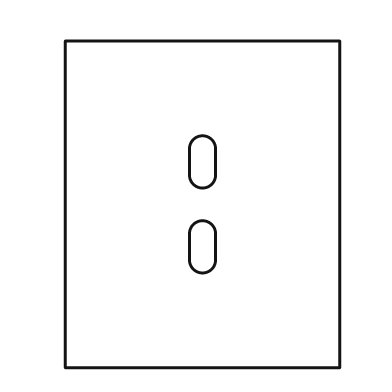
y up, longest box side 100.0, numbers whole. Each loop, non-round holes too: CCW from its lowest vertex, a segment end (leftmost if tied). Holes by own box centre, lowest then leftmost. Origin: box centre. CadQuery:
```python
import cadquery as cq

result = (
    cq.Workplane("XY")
    .moveTo(-42.0, -50.0)
    .lineTo(42.0, -50.0)
    .lineTo(42.0, 50.0)
    .lineTo(-42.0, 50.0)
    .close()
    .moveTo(-4.0, -17.0)
    .threePointArc((0.0, -21.0), (4.0, -17.0))
    .lineTo(4.0, -9.0)
    .threePointArc((0.0, -5.0), (-4.0, -9.0))
    .close()
    .moveTo(-4.0, 9.0)
    .threePointArc((0.0, 5.0), (4.0, 9.0))
    .lineTo(4.0, 17.0)
    .threePointArc((0.0, 21.0), (-4.0, 17.0))
    .close()
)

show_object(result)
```